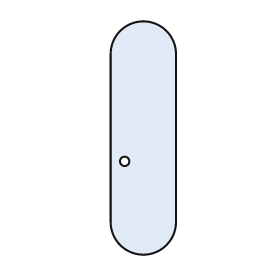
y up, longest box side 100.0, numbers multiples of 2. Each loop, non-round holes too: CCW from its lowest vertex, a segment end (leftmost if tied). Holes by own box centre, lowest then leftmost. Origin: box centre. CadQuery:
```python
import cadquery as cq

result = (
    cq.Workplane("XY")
    .moveTo(-14.0, -36.0)
    .threePointArc((0.0, -50.0), (14.0, -36.0))
    .lineTo(14.0, 36.0)
    .threePointArc((0.0, 50.0), (-14.0, 36.0))
    .close()
    .moveTo(-8.0, -10.0)
    .circle(2.0)
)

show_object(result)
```